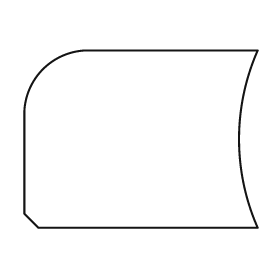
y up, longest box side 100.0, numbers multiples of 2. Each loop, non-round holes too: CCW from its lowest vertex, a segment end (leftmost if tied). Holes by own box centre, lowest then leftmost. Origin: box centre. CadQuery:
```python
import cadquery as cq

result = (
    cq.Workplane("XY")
    .moveTo(-44.0, -38.0)
    .lineTo(50.0, -38.0)
    .threePointArc((42.0, 0.0), (50.0, 38.0))
    .lineTo(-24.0, 38.0)
    .threePointArc((-42.0, 30.0), (-50.0, 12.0))
    .lineTo(-50.0, -32.0)
    .close()
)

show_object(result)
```